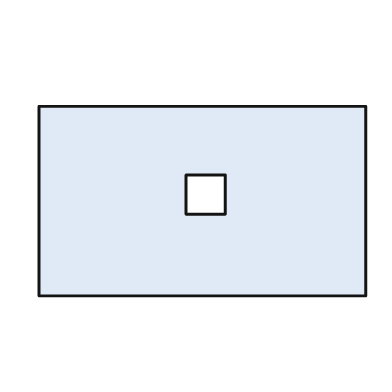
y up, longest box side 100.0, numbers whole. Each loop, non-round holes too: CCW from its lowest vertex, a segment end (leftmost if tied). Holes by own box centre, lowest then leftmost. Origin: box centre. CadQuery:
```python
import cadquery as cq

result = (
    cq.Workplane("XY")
    .moveTo(-50.0, -29.0)
    .lineTo(50.0, -29.0)
    .lineTo(50.0, 29.0)
    .lineTo(-50.0, 29.0)
    .close()
    .moveTo(-5.0, -4.0)
    .lineTo(7.0, -4.0)
    .lineTo(7.0, 8.0)
    .lineTo(-5.0, 8.0)
    .close()
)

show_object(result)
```